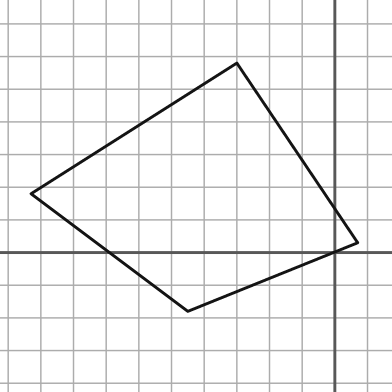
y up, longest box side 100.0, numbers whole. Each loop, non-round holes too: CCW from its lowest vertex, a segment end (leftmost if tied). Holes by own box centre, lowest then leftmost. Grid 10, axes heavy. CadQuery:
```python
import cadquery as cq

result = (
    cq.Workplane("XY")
    .moveTo(-45.0, -18.0)
    .lineTo(7.0, 3.0)
    .lineTo(-30.0, 58.0)
    .lineTo(-93.0, 18.0)
    .close()
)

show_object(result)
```